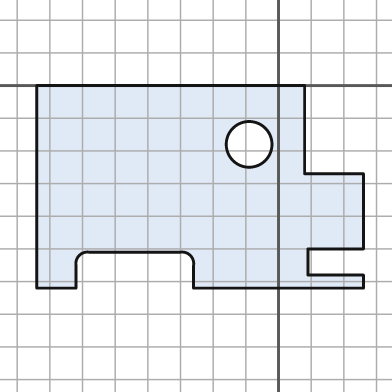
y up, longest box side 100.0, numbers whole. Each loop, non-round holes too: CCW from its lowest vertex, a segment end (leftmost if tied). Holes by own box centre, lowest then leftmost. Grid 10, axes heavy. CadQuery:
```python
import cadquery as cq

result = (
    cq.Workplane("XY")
    .moveTo(-74.0, -62.0)
    .lineTo(-62.0, -62.0)
    .lineTo(-62.0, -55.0)
    .threePointArc((-61.0, -52.0), (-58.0, -51.0))
    .lineTo(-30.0, -51.0)
    .threePointArc((-27.0, -52.0), (-26.0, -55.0))
    .lineTo(-26.0, -62.0)
    .lineTo(26.0, -62.0)
    .lineTo(26.0, -58.0)
    .lineTo(9.0, -58.0)
    .lineTo(9.0, -50.0)
    .lineTo(26.0, -50.0)
    .lineTo(26.0, -27.0)
    .lineTo(8.0, -27.0)
    .lineTo(8.0, 0.0)
    .lineTo(-74.0, 0.0)
    .close()
    .moveTo(-9.0, -18.0)
    .circle(7.0)
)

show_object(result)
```